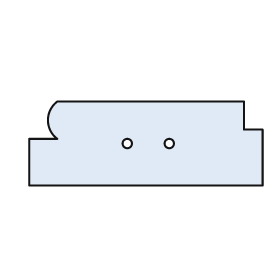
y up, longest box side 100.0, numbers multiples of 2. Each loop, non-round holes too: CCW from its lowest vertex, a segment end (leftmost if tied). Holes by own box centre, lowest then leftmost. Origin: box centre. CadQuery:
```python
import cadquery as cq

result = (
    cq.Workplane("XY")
    .moveTo(-50.0, -18.0)
    .lineTo(50.0, -18.0)
    .lineTo(50.0, 6.0)
    .lineTo(42.0, 6.0)
    .lineTo(42.0, 18.0)
    .lineTo(-38.0, 18.0)
    .threePointArc((-42.0, 10.0), (-38.0, 2.0))
    .lineTo(-50.0, 2.0)
    .close()
    .moveTo(-8.0, 0.0)
    .circle(2.0)
    .moveTo(10.0, 0.0)
    .circle(2.0)
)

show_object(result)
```